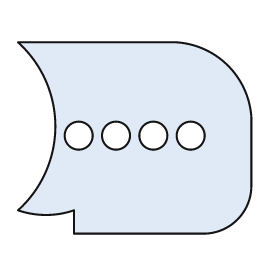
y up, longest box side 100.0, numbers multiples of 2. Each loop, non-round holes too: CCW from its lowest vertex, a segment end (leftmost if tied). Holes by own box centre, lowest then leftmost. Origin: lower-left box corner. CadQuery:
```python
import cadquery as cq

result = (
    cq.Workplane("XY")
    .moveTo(24.0, 0.0)
    .lineTo(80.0, 0.0)
    .threePointArc((94.0, 6.0), (100.0, 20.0))
    .lineTo(100.0, 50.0)
    .threePointArc((90.0, 72.0), (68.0, 82.0))
    .lineTo(0.0, 82.0)
    .threePointArc((16.0, 46.0), (0.0, 10.0))
    .threePointArc((12.0, 8.0), (24.0, 10.0))
    .close()
    .moveTo(26.0, 42.0)
    .circle(6.0)
    .moveTo(42.0, 42.0)
    .circle(6.0)
    .moveTo(58.0, 42.0)
    .circle(6.0)
    .moveTo(74.0, 42.0)
    .circle(6.0)
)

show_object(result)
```